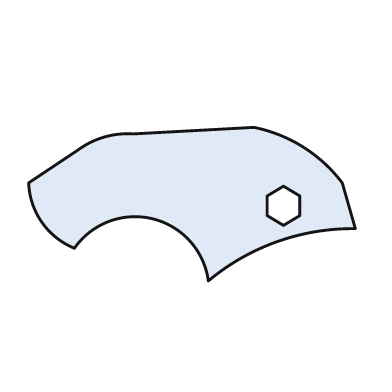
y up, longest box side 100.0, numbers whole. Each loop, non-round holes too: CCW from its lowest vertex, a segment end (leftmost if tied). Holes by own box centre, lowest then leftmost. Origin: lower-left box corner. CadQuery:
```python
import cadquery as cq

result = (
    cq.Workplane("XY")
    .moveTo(55.0, 0.0)
    .threePointArc((76.0, 12.0), (100.0, 16.0))
    .lineTo(96.0, 30.0)
    .threePointArc((84.0, 41.0), (69.0, 47.0))
    .lineTo(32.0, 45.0)
    .threePointArc((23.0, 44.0), (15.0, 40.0))
    .lineTo(0.0, 30.0)
    .threePointArc((4.0, 18.0), (14.0, 10.0))
    .threePointArc((38.0, 19.0), (55.0, 0.0))
    .close()
    .moveTo(78.0, 17.0)
    .lineTo(83.0, 20.0)
    .lineTo(83.0, 26.0)
    .lineTo(78.0, 29.0)
    .lineTo(73.0, 26.0)
    .lineTo(73.0, 20.0)
    .close()
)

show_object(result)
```